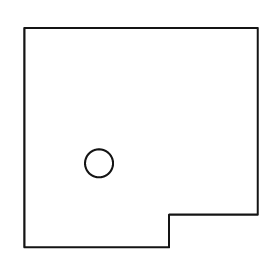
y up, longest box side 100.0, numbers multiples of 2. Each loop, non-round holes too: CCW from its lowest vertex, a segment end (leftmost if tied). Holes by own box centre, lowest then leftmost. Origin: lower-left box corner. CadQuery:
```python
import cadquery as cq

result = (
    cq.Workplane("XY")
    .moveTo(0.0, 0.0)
    .lineTo(62.0, 0.0)
    .lineTo(62.0, 14.0)
    .lineTo(100.0, 14.0)
    .lineTo(100.0, 94.0)
    .lineTo(0.0, 94.0)
    .close()
    .moveTo(32.0, 36.0)
    .circle(6.0)
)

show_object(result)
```